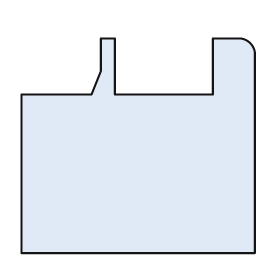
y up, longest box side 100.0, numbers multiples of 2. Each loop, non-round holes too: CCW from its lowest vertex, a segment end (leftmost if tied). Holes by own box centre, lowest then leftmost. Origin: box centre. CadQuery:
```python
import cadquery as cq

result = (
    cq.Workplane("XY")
    .moveTo(-50.0, -46.0)
    .lineTo(50.0, -46.0)
    .lineTo(50.0, 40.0)
    .threePointArc((48.0, 44.0), (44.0, 46.0))
    .lineTo(32.0, 46.0)
    .lineTo(32.0, 22.0)
    .lineTo(-10.0, 22.0)
    .lineTo(-10.0, 46.0)
    .lineTo(-16.0, 46.0)
    .lineTo(-16.0, 32.0)
    .lineTo(-20.0, 22.0)
    .lineTo(-50.0, 22.0)
    .close()
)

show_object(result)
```